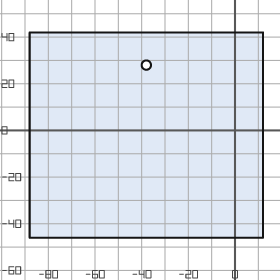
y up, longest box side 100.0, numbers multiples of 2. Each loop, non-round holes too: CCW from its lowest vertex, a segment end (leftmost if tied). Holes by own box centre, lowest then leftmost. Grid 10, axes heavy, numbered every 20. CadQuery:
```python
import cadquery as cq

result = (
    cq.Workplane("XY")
    .moveTo(-88.0, -46.0)
    .lineTo(12.0, -46.0)
    .lineTo(12.0, 42.0)
    .lineTo(-88.0, 42.0)
    .close()
    .moveTo(-38.0, 28.0)
    .circle(2.0)
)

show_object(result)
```